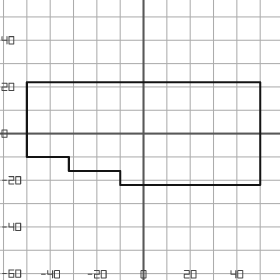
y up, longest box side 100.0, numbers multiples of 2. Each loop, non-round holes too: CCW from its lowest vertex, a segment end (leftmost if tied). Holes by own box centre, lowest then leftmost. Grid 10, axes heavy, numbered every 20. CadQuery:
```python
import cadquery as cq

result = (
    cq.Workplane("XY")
    .moveTo(-10.0, -22.0)
    .lineTo(50.0, -22.0)
    .lineTo(50.0, 22.0)
    .lineTo(-50.0, 22.0)
    .lineTo(-50.0, -10.0)
    .lineTo(-32.0, -10.0)
    .lineTo(-32.0, -16.0)
    .lineTo(-10.0, -16.0)
    .close()
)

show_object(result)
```